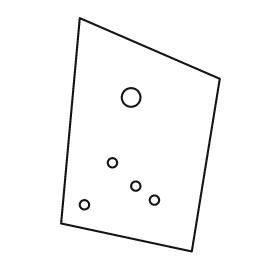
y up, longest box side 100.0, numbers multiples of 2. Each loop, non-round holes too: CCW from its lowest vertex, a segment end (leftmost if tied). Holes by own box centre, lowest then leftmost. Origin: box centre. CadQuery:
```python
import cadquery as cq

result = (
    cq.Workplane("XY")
    .moveTo(22.0, -50.0)
    .lineTo(34.0, 24.0)
    .lineTo(-26.0, 50.0)
    .lineTo(-34.0, -38.0)
    .close()
    .moveTo(-24.0, -30.0)
    .circle(2.0)
    .moveTo(6.0, -28.0)
    .circle(2.0)
    .moveTo(-2.0, -22.0)
    .circle(2.0)
    .moveTo(-12.0, -12.0)
    .circle(2.0)
    .moveTo(-4.0, 16.0)
    .circle(4.0)
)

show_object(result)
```